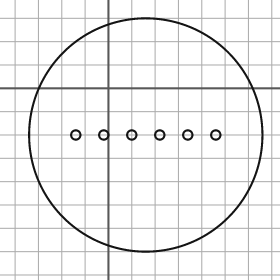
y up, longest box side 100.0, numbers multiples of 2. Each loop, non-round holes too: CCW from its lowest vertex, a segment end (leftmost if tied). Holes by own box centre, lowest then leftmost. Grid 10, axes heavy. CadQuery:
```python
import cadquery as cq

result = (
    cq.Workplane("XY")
    .moveTo(16.0, -20.0)
    .circle(50.0)
    .moveTo(-14.0, -20.0)
    .circle(2.0)
    .moveTo(-2.0, -20.0)
    .circle(2.0)
    .moveTo(10.0, -20.0)
    .circle(2.0)
    .moveTo(22.0, -20.0)
    .circle(2.0)
    .moveTo(34.0, -20.0)
    .circle(2.0)
    .moveTo(46.0, -20.0)
    .circle(2.0)
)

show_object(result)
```